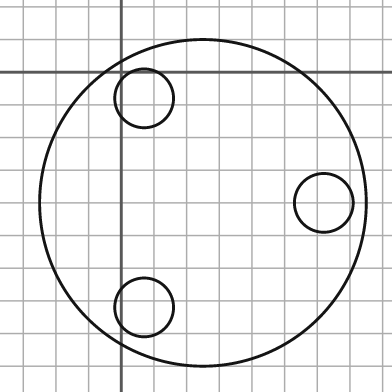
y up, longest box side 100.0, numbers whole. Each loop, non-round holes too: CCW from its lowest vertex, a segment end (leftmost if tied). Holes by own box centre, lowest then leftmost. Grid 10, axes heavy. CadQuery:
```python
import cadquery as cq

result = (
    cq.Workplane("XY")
    .moveTo(25.0, -40.0)
    .circle(50.0)
    .moveTo(7.0, -72.0)
    .circle(9.0)
    .moveTo(62.0, -40.0)
    .circle(9.0)
    .moveTo(7.0, -8.0)
    .circle(9.0)
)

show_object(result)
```